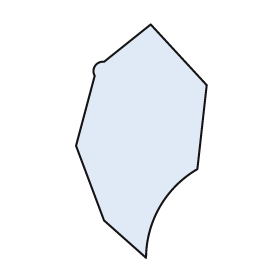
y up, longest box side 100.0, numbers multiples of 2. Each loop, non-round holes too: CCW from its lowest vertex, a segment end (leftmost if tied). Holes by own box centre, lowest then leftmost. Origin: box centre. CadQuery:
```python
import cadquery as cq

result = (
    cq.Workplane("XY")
    .moveTo(2.0, -50.0)
    .threePointArc((8.0, -28.0), (24.0, -12.0))
    .lineTo(28.0, 24.0)
    .lineTo(4.0, 50.0)
    .lineTo(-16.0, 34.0)
    .threePointArc((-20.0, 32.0), (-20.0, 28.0))
    .lineTo(-28.0, -2.0)
    .lineTo(-16.0, -34.0)
    .close()
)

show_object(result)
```